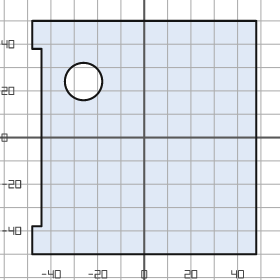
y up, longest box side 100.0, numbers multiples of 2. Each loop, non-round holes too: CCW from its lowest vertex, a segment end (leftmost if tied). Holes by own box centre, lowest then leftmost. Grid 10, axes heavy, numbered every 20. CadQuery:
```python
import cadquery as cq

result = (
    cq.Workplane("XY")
    .moveTo(-48.0, -50.0)
    .lineTo(48.0, -50.0)
    .lineTo(48.0, 50.0)
    .lineTo(-48.0, 50.0)
    .lineTo(-48.0, 38.0)
    .lineTo(-44.0, 38.0)
    .lineTo(-44.0, -38.0)
    .lineTo(-48.0, -38.0)
    .close()
    .moveTo(-26.0, 24.0)
    .circle(8.0)
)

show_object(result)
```